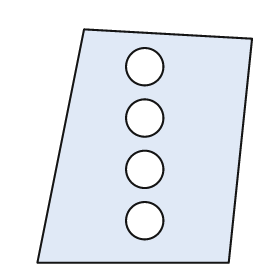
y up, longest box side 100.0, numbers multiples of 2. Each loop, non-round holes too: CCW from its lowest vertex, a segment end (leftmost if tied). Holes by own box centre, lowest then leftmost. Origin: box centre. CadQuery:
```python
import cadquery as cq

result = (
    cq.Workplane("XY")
    .moveTo(-46.0, -50.0)
    .lineTo(36.0, -50.0)
    .lineTo(46.0, 46.0)
    .lineTo(-26.0, 50.0)
    .close()
    .moveTo(0.0, -32.0)
    .circle(8.0)
    .moveTo(0.0, -10.0)
    .circle(8.0)
    .moveTo(0.0, 12.0)
    .circle(8.0)
    .moveTo(0.0, 34.0)
    .circle(8.0)
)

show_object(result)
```